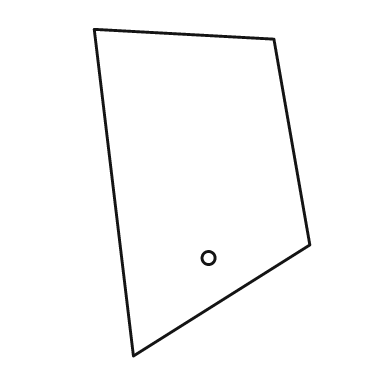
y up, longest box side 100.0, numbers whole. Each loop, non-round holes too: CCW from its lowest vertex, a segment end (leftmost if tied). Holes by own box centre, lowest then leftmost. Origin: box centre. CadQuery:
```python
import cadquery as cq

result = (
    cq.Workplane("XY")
    .moveTo(-21.0, -50.0)
    .lineTo(33.0, -16.0)
    .lineTo(22.0, 47.0)
    .lineTo(-33.0, 50.0)
    .close()
    .moveTo(2.0, -20.0)
    .circle(2.0)
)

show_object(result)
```